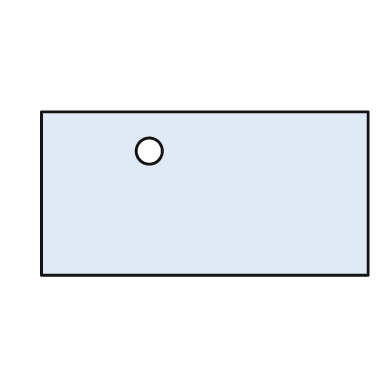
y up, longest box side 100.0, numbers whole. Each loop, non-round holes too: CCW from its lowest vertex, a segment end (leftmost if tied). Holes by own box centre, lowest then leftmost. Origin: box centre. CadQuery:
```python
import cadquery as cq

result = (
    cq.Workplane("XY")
    .moveTo(-50.0, -25.0)
    .lineTo(50.0, -25.0)
    .lineTo(50.0, 25.0)
    .lineTo(-50.0, 25.0)
    .close()
    .moveTo(-17.0, 13.0)
    .circle(4.0)
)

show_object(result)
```